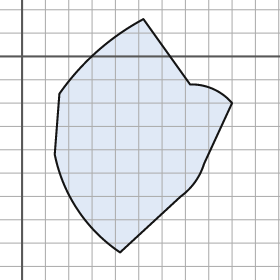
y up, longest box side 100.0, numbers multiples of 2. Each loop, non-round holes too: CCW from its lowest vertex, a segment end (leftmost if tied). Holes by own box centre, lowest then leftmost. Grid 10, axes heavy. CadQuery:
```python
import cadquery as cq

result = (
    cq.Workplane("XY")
    .moveTo(42.0, -84.0)
    .lineTo(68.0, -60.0)
    .threePointArc((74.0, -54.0), (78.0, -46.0))
    .lineTo(90.0, -20.0)
    .threePointArc((82.0, -14.0), (72.0, -12.0))
    .lineTo(52.0, 16.0)
    .threePointArc((32.0, 2.0), (16.0, -16.0))
    .lineTo(14.0, -42.0)
    .threePointArc((24.0, -66.0), (42.0, -84.0))
    .close()
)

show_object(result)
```